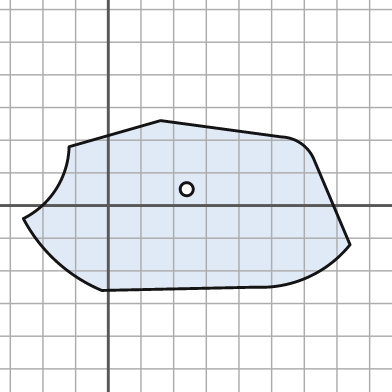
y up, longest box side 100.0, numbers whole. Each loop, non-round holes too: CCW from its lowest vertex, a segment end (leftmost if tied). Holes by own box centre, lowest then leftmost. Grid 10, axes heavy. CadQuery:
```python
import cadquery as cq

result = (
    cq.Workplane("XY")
    .moveTo(-2.0, -26.0)
    .lineTo(45.0, -25.0)
    .threePointArc((61.0, -22.0), (74.0, -12.0))
    .lineTo(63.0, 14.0)
    .threePointArc((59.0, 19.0), (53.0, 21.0))
    .lineTo(16.0, 26.0)
    .lineTo(-12.0, 18.0)
    .threePointArc((-16.0, 5.0), (-26.0, -4.0))
    .threePointArc((-16.0, -17.0), (-2.0, -26.0))
    .close()
    .moveTo(24.0, 5.0)
    .circle(2.0)
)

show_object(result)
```